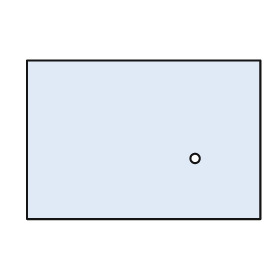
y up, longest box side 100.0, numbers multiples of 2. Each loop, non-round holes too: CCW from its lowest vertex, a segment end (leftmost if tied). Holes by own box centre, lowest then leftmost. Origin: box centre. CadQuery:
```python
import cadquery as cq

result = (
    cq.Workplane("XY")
    .moveTo(-50.0, -34.0)
    .lineTo(50.0, -34.0)
    .lineTo(50.0, 34.0)
    .lineTo(-50.0, 34.0)
    .close()
    .moveTo(22.0, -8.0)
    .circle(2.0)
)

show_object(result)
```